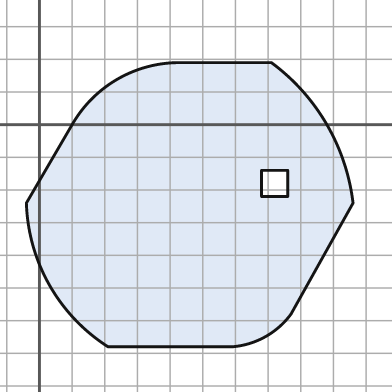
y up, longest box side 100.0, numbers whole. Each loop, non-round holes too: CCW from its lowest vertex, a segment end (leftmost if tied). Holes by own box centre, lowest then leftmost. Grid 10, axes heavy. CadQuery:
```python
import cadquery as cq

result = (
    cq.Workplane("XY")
    .moveTo(21.0, -68.0)
    .lineTo(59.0, -68.0)
    .threePointArc((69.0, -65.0), (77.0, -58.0))
    .lineTo(96.0, -24.0)
    .threePointArc((88.0, 0.0), (71.0, 19.0))
    .lineTo(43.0, 19.0)
    .threePointArc((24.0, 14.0), (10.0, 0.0))
    .lineTo(-4.0, -24.0)
    .threePointArc((3.0, -49.0), (21.0, -68.0))
    .close()
    .moveTo(68.0, -22.0)
    .lineTo(76.0, -22.0)
    .lineTo(76.0, -14.0)
    .lineTo(68.0, -14.0)
    .close()
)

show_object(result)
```